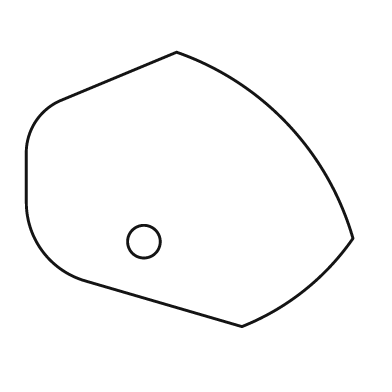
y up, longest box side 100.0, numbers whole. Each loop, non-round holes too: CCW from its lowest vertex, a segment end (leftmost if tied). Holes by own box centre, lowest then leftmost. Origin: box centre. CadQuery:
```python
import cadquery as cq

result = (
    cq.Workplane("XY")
    .moveTo(16.0, -42.0)
    .threePointArc((35.0, -31.0), (50.0, -15.0))
    .threePointArc((30.0, 20.0), (-4.0, 42.0))
    .lineTo(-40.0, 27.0)
    .threePointArc((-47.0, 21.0), (-50.0, 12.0))
    .lineTo(-50.0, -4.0)
    .threePointArc((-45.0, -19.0), (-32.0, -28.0))
    .close()
    .moveTo(-14.0, -16.0)
    .circle(5.0)
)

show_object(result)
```